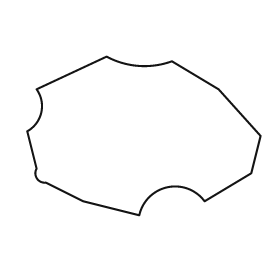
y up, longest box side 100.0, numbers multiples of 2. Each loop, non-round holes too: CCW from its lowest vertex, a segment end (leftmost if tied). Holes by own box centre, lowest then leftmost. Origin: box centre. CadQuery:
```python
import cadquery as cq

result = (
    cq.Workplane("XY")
    .moveTo(-2.0, -34.0)
    .threePointArc((10.0, -22.0), (26.0, -28.0))
    .lineTo(46.0, -16.0)
    .lineTo(50.0, 0.0)
    .lineTo(32.0, 20.0)
    .lineTo(12.0, 32.0)
    .threePointArc((-2.0, 30.0), (-16.0, 34.0))
    .lineTo(-46.0, 20.0)
    .threePointArc((-44.0, 10.0), (-50.0, 2.0))
    .lineTo(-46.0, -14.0)
    .threePointArc((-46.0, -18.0), (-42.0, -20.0))
    .lineTo(-26.0, -28.0)
    .close()
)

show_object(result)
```